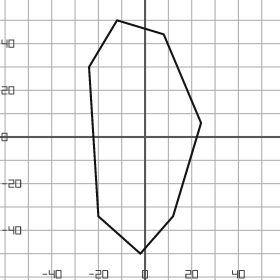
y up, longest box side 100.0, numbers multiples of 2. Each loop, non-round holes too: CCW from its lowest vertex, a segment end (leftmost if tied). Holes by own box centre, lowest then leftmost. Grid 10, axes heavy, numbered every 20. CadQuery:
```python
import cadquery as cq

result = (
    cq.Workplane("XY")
    .moveTo(-2.0, -50.0)
    .lineTo(12.0, -34.0)
    .lineTo(24.0, 6.0)
    .lineTo(8.0, 44.0)
    .lineTo(-12.0, 50.0)
    .lineTo(-24.0, 30.0)
    .lineTo(-20.0, -34.0)
    .close()
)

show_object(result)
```